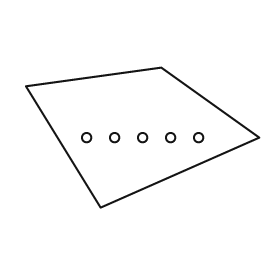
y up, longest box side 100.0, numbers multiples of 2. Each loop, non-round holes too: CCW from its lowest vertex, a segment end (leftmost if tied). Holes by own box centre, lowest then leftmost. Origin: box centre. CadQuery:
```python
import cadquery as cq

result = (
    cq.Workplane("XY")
    .moveTo(-18.0, -30.0)
    .lineTo(50.0, 0.0)
    .lineTo(8.0, 30.0)
    .lineTo(-50.0, 22.0)
    .close()
    .moveTo(-24.0, 0.0)
    .circle(2.0)
    .moveTo(-12.0, 0.0)
    .circle(2.0)
    .moveTo(0.0, 0.0)
    .circle(2.0)
    .moveTo(12.0, 0.0)
    .circle(2.0)
    .moveTo(24.0, 0.0)
    .circle(2.0)
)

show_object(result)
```